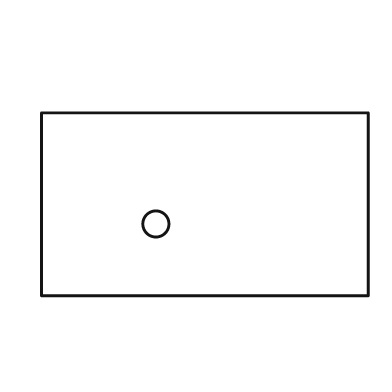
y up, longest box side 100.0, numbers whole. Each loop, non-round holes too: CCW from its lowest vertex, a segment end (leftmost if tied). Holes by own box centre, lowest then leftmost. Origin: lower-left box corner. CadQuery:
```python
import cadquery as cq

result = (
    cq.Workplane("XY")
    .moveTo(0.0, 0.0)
    .lineTo(100.0, 0.0)
    .lineTo(100.0, 56.0)
    .lineTo(0.0, 56.0)
    .close()
    .moveTo(35.0, 22.0)
    .circle(4.0)
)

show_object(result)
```